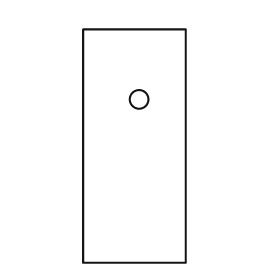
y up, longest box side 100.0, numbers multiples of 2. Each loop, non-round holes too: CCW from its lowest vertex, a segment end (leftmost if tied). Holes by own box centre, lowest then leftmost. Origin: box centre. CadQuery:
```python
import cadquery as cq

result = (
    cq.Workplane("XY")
    .moveTo(-22.0, -50.0)
    .lineTo(22.0, -50.0)
    .lineTo(22.0, 50.0)
    .lineTo(-22.0, 50.0)
    .close()
    .moveTo(2.0, 20.0)
    .circle(4.0)
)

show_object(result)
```